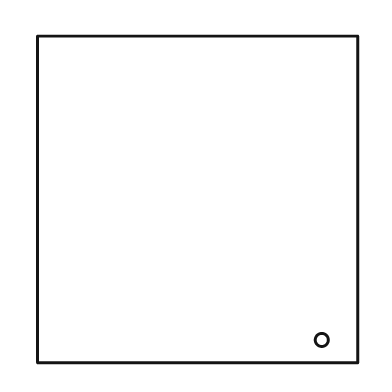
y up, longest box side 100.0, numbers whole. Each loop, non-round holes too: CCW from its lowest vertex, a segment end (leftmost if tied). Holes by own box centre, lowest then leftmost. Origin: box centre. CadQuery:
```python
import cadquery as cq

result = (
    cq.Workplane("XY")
    .moveTo(-49.0, -50.0)
    .lineTo(49.0, -50.0)
    .lineTo(49.0, 50.0)
    .lineTo(-49.0, 50.0)
    .close()
    .moveTo(38.0, -43.0)
    .circle(2.0)
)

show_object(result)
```